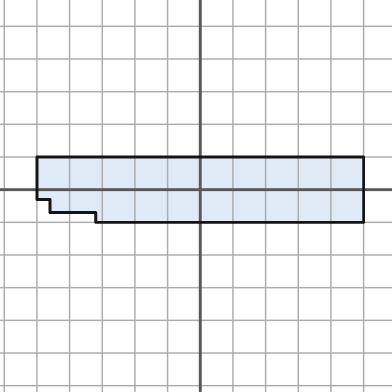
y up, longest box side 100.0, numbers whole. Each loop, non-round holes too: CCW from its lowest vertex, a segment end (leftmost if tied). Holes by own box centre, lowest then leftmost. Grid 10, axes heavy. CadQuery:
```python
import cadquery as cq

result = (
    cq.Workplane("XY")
    .moveTo(-32.0, -10.0)
    .lineTo(50.0, -10.0)
    .lineTo(50.0, 10.0)
    .lineTo(-50.0, 10.0)
    .lineTo(-50.0, -3.0)
    .lineTo(-46.0, -3.0)
    .lineTo(-46.0, -7.0)
    .lineTo(-32.0, -7.0)
    .close()
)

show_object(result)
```